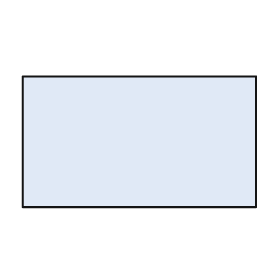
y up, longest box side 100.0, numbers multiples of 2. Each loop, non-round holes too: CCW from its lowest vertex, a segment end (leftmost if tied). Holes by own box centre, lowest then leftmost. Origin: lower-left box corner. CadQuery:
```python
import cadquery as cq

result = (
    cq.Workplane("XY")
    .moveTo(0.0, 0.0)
    .lineTo(100.0, 0.0)
    .lineTo(100.0, 56.0)
    .lineTo(0.0, 56.0)
    .close()
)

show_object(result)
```